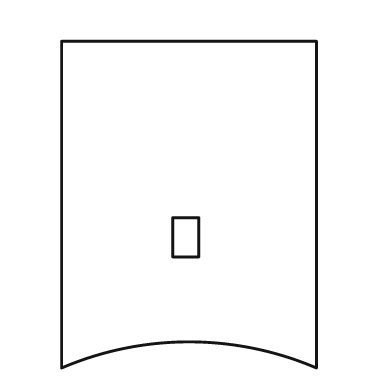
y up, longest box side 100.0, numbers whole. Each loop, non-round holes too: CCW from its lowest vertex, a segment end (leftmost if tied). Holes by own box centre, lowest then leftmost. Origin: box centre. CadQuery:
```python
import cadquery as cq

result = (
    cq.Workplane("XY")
    .moveTo(-39.0, -50.0)
    .threePointArc((0.0, -42.0), (39.0, -50.0))
    .lineTo(39.0, 50.0)
    .lineTo(-39.0, 50.0)
    .close()
    .moveTo(-5.0, -16.0)
    .lineTo(3.0, -16.0)
    .lineTo(3.0, -4.0)
    .lineTo(-5.0, -4.0)
    .close()
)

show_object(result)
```